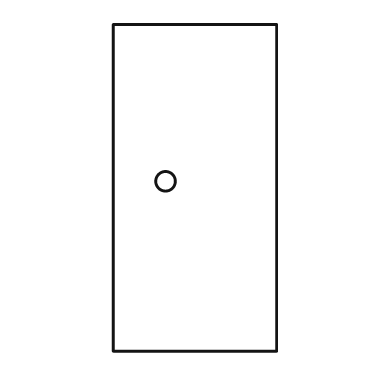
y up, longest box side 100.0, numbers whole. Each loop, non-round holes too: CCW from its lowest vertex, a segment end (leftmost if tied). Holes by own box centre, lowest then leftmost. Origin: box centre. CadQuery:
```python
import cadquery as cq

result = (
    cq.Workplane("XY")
    .moveTo(-25.0, -50.0)
    .lineTo(25.0, -50.0)
    .lineTo(25.0, 50.0)
    .lineTo(-25.0, 50.0)
    .close()
    .moveTo(-9.0, 2.0)
    .circle(3.0)
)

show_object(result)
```